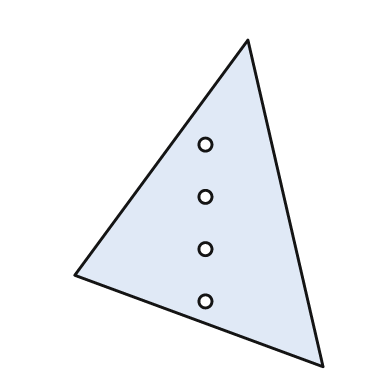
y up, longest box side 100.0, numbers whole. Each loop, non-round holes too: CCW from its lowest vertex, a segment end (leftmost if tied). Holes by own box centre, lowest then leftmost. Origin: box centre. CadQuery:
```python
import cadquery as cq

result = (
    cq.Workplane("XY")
    .moveTo(38.0, -50.0)
    .lineTo(15.0, 50.0)
    .lineTo(-38.0, -22.0)
    .close()
    .moveTo(2.0, -30.0)
    .circle(2.0)
    .moveTo(2.0, -14.0)
    .circle(2.0)
    .moveTo(2.0, 2.0)
    .circle(2.0)
    .moveTo(2.0, 18.0)
    .circle(2.0)
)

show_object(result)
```